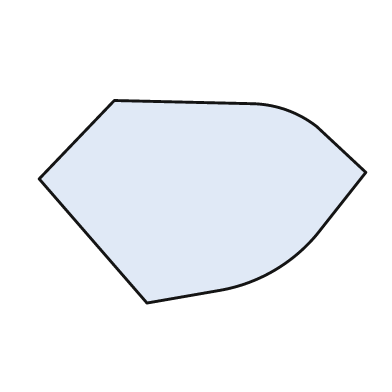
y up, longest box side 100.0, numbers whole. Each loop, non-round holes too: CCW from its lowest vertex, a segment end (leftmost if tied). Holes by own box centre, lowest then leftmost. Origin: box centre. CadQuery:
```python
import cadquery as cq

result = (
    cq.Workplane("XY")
    .moveTo(-17.0, -31.0)
    .lineTo(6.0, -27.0)
    .threePointArc((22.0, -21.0), (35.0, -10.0))
    .lineTo(50.0, 9.0)
    .lineTo(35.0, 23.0)
    .threePointArc((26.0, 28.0), (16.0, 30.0))
    .lineTo(-27.0, 31.0)
    .lineTo(-50.0, 7.0)
    .close()
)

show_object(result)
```